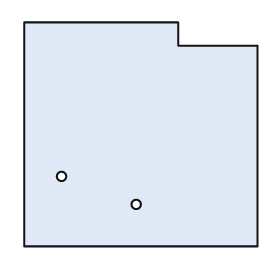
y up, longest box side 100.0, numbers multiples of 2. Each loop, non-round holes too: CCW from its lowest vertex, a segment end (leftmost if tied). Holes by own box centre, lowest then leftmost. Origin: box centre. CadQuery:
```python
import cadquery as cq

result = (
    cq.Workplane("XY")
    .moveTo(-50.0, -48.0)
    .lineTo(50.0, -48.0)
    .lineTo(50.0, 38.0)
    .lineTo(16.0, 38.0)
    .lineTo(16.0, 48.0)
    .lineTo(-50.0, 48.0)
    .close()
    .moveTo(-2.0, -30.0)
    .circle(2.0)
    .moveTo(-34.0, -18.0)
    .circle(2.0)
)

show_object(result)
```